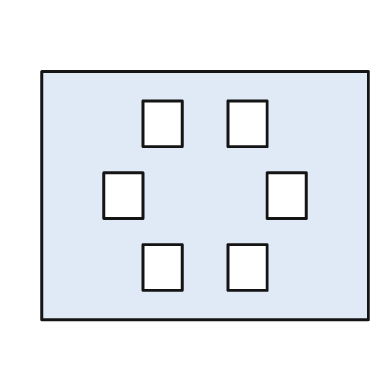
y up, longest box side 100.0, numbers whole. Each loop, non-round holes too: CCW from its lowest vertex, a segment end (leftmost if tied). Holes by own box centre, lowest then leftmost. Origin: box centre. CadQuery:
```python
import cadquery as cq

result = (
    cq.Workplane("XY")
    .moveTo(-50.0, -38.0)
    .lineTo(50.0, -38.0)
    .lineTo(50.0, 38.0)
    .lineTo(-50.0, 38.0)
    .close()
    .moveTo(-19.0, -29.0)
    .lineTo(-7.0, -29.0)
    .lineTo(-7.0, -15.0)
    .lineTo(-19.0, -15.0)
    .close()
    .moveTo(7.0, -29.0)
    .lineTo(19.0, -29.0)
    .lineTo(19.0, -15.0)
    .lineTo(7.0, -15.0)
    .close()
    .moveTo(-31.0, -7.0)
    .lineTo(-19.0, -7.0)
    .lineTo(-19.0, 7.0)
    .lineTo(-31.0, 7.0)
    .close()
    .moveTo(19.0, -7.0)
    .lineTo(31.0, -7.0)
    .lineTo(31.0, 7.0)
    .lineTo(19.0, 7.0)
    .close()
    .moveTo(-19.0, 15.0)
    .lineTo(-7.0, 15.0)
    .lineTo(-7.0, 29.0)
    .lineTo(-19.0, 29.0)
    .close()
    .moveTo(7.0, 15.0)
    .lineTo(19.0, 15.0)
    .lineTo(19.0, 29.0)
    .lineTo(7.0, 29.0)
    .close()
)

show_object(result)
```